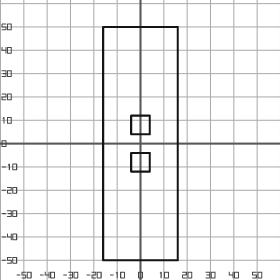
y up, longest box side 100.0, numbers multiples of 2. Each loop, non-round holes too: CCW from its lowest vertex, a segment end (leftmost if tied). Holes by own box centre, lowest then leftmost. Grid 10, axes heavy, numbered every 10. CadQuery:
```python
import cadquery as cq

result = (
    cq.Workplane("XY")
    .moveTo(-16.0, -50.0)
    .lineTo(16.0, -50.0)
    .lineTo(16.0, 50.0)
    .lineTo(-16.0, 50.0)
    .close()
    .moveTo(-4.0, -12.0)
    .lineTo(4.0, -12.0)
    .lineTo(4.0, -4.0)
    .lineTo(-4.0, -4.0)
    .close()
    .moveTo(-4.0, 4.0)
    .lineTo(4.0, 4.0)
    .lineTo(4.0, 12.0)
    .lineTo(-4.0, 12.0)
    .close()
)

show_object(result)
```